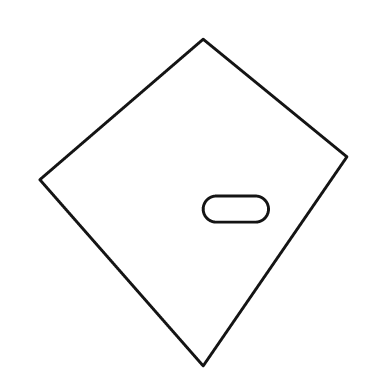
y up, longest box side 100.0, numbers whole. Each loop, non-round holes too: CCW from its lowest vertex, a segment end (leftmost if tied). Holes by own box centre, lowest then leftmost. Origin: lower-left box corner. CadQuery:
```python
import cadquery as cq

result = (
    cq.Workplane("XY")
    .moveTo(50.0, 0.0)
    .lineTo(94.0, 64.0)
    .lineTo(50.0, 100.0)
    .lineTo(0.0, 57.0)
    .close()
    .moveTo(54.0, 44.0)
    .lineTo(66.0, 44.0)
    .threePointArc((70.0, 48.0), (66.0, 52.0))
    .lineTo(54.0, 52.0)
    .threePointArc((50.0, 48.0), (54.0, 44.0))
    .close()
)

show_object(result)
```